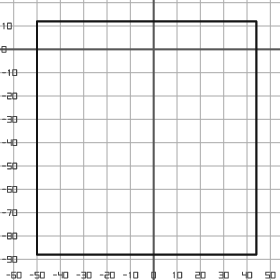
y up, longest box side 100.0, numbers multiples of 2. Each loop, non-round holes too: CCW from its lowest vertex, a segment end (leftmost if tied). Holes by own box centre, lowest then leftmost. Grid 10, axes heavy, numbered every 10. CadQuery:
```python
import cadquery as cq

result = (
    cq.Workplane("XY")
    .moveTo(-50.0, -88.0)
    .lineTo(44.0, -88.0)
    .lineTo(44.0, 12.0)
    .lineTo(-50.0, 12.0)
    .close()
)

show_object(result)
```